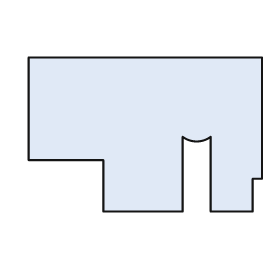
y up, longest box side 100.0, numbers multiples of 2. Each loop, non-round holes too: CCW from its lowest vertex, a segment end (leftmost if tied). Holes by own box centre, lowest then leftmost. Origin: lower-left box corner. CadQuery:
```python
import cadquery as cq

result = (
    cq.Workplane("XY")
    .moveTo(32.0, 0.0)
    .lineTo(66.0, 0.0)
    .lineTo(66.0, 32.0)
    .threePointArc((72.0, 30.0), (78.0, 32.0))
    .lineTo(78.0, 0.0)
    .lineTo(96.0, 0.0)
    .lineTo(96.0, 14.0)
    .lineTo(100.0, 14.0)
    .lineTo(100.0, 66.0)
    .lineTo(0.0, 66.0)
    .lineTo(0.0, 22.0)
    .lineTo(32.0, 22.0)
    .close()
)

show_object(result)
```